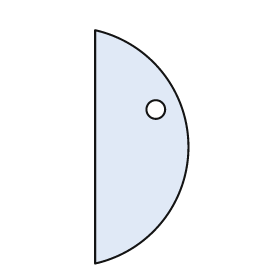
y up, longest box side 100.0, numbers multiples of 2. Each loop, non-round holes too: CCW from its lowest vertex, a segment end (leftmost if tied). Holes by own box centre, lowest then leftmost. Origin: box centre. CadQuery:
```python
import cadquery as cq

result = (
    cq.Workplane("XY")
    .moveTo(-20.0, -50.0)
    .threePointArc((20.0, 0.0), (-20.0, 50.0))
    .close()
    .moveTo(6.0, 16.0)
    .circle(4.0)
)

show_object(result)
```